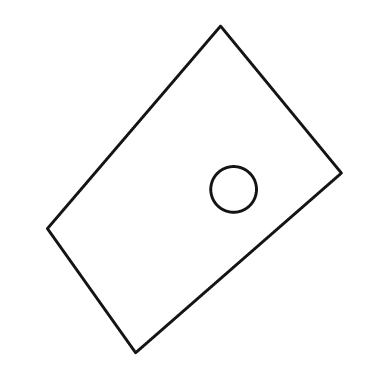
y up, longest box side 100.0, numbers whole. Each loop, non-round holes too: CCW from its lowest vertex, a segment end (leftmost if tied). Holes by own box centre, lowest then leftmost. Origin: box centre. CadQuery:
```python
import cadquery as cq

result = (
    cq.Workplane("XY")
    .moveTo(-18.0, -50.0)
    .lineTo(45.0, 5.0)
    .lineTo(8.0, 50.0)
    .lineTo(-45.0, -12.0)
    .close()
    .moveTo(12.0, 0.0)
    .circle(7.0)
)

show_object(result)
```